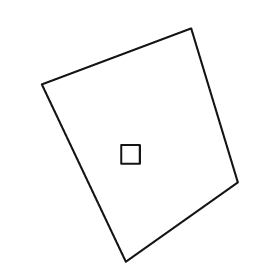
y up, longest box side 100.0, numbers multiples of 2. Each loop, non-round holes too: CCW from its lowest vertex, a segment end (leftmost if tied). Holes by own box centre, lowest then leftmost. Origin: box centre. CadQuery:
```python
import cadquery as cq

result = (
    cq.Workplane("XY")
    .moveTo(-6.0, -50.0)
    .lineTo(42.0, -16.0)
    .lineTo(22.0, 50.0)
    .lineTo(-42.0, 26.0)
    .close()
    .moveTo(-8.0, -8.0)
    .lineTo(0.0, -8.0)
    .lineTo(0.0, 0.0)
    .lineTo(-8.0, 0.0)
    .close()
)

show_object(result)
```